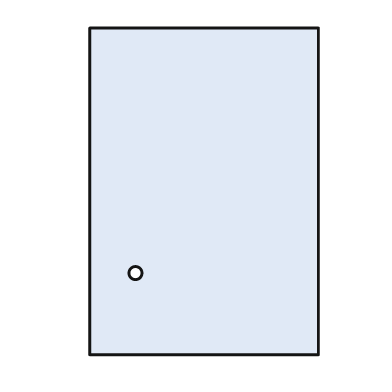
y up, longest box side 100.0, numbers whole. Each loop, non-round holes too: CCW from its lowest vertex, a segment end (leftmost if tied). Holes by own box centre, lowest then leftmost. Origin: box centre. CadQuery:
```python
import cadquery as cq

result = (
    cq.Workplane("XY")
    .moveTo(-35.0, -50.0)
    .lineTo(35.0, -50.0)
    .lineTo(35.0, 50.0)
    .lineTo(-35.0, 50.0)
    .close()
    .moveTo(-21.0, -25.0)
    .circle(2.0)
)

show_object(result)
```